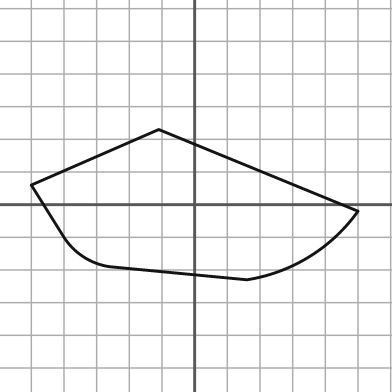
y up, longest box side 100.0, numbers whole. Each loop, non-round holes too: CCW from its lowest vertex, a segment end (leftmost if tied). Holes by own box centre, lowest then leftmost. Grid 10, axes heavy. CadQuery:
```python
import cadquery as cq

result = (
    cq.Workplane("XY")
    .moveTo(16.0, -23.0)
    .threePointArc((35.0, -16.0), (50.0, -2.0))
    .lineTo(-11.0, 23.0)
    .lineTo(-50.0, 6.0)
    .lineTo(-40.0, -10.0)
    .threePointArc((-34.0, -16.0), (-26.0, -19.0))
    .close()
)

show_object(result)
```